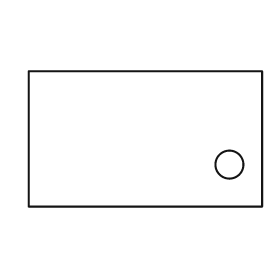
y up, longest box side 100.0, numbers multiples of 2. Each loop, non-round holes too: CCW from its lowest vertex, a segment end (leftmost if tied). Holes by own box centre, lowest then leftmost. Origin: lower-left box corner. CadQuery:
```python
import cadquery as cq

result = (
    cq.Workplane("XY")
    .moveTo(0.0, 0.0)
    .lineTo(100.0, 0.0)
    .lineTo(100.0, 58.0)
    .lineTo(0.0, 58.0)
    .close()
    .moveTo(86.0, 18.0)
    .circle(6.0)
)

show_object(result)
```